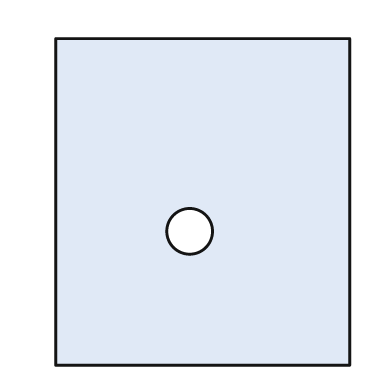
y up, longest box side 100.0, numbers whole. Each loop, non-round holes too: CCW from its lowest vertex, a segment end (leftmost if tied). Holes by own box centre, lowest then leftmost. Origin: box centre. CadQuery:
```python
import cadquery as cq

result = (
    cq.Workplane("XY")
    .moveTo(-45.0, -50.0)
    .lineTo(45.0, -50.0)
    .lineTo(45.0, 50.0)
    .lineTo(-45.0, 50.0)
    .close()
    .moveTo(-4.0, -9.0)
    .circle(7.0)
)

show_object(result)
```